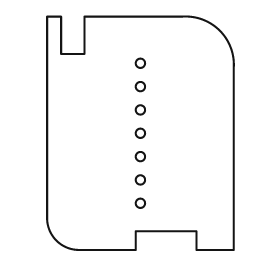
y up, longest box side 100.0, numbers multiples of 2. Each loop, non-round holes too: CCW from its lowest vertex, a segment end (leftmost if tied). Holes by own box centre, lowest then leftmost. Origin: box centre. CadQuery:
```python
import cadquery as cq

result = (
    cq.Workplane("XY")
    .moveTo(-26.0, -50.0)
    .lineTo(-2.0, -50.0)
    .lineTo(-2.0, -42.0)
    .lineTo(24.0, -42.0)
    .lineTo(24.0, -50.0)
    .lineTo(40.0, -50.0)
    .lineTo(40.0, 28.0)
    .threePointArc((34.0, 44.0), (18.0, 50.0))
    .lineTo(-24.0, 50.0)
    .lineTo(-24.0, 34.0)
    .lineTo(-34.0, 34.0)
    .lineTo(-34.0, 50.0)
    .lineTo(-40.0, 50.0)
    .lineTo(-40.0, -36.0)
    .threePointArc((-36.0, -46.0), (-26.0, -50.0))
    .close()
    .moveTo(0.0, -30.0)
    .circle(2.0)
    .moveTo(0.0, -20.0)
    .circle(2.0)
    .moveTo(0.0, -10.0)
    .circle(2.0)
    .moveTo(0.0, 0.0)
    .circle(2.0)
    .moveTo(0.0, 10.0)
    .circle(2.0)
    .moveTo(0.0, 20.0)
    .circle(2.0)
    .moveTo(0.0, 30.0)
    .circle(2.0)
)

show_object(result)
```